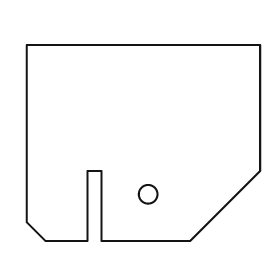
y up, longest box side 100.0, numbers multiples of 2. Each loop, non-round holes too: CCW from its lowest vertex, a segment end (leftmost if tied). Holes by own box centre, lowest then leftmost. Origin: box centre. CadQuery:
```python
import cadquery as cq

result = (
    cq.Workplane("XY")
    .moveTo(-42.0, -42.0)
    .lineTo(-24.0, -42.0)
    .lineTo(-24.0, -12.0)
    .lineTo(-18.0, -12.0)
    .lineTo(-18.0, -42.0)
    .lineTo(20.0, -42.0)
    .lineTo(50.0, -12.0)
    .lineTo(50.0, 42.0)
    .lineTo(-50.0, 42.0)
    .lineTo(-50.0, -34.0)
    .close()
    .moveTo(2.0, -22.0)
    .circle(4.0)
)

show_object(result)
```